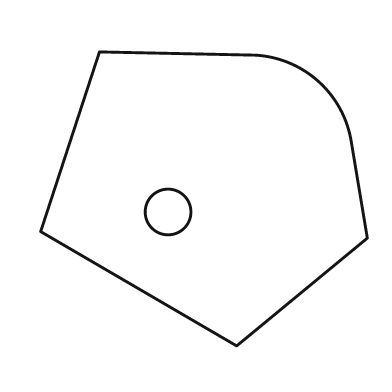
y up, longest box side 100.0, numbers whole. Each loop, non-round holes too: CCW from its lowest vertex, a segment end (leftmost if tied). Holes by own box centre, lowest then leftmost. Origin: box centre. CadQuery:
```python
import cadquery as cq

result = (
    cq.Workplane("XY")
    .moveTo(10.0, -45.0)
    .lineTo(50.0, -12.0)
    .lineTo(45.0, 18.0)
    .threePointArc((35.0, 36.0), (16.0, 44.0))
    .lineTo(-32.0, 45.0)
    .lineTo(-50.0, -10.0)
    .close()
    .moveTo(-11.0, -4.0)
    .circle(7.0)
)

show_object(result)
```